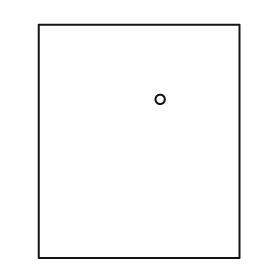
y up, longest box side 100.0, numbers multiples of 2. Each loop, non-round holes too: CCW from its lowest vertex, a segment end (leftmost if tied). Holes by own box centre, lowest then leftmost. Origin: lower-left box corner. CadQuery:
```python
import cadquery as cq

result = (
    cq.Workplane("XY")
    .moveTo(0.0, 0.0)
    .lineTo(86.0, 0.0)
    .lineTo(86.0, 100.0)
    .lineTo(0.0, 100.0)
    .close()
    .moveTo(52.0, 68.0)
    .circle(2.0)
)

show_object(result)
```